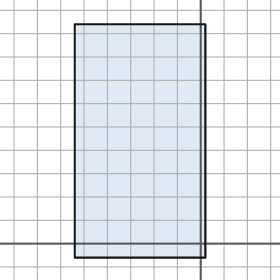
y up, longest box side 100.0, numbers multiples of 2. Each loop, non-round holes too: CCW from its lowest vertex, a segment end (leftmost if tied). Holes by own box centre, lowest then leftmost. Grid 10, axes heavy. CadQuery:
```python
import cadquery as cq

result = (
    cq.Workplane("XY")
    .moveTo(-54.0, -6.0)
    .lineTo(2.0, -6.0)
    .lineTo(2.0, 94.0)
    .lineTo(-54.0, 94.0)
    .close()
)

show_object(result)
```